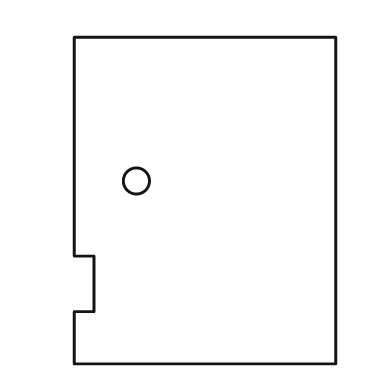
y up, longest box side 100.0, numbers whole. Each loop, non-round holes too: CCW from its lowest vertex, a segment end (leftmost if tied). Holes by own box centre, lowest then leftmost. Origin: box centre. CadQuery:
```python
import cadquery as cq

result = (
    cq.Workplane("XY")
    .moveTo(-40.0, -50.0)
    .lineTo(40.0, -50.0)
    .lineTo(40.0, 50.0)
    .lineTo(-40.0, 50.0)
    .lineTo(-40.0, -17.0)
    .lineTo(-34.0, -17.0)
    .lineTo(-34.0, -34.0)
    .lineTo(-40.0, -34.0)
    .close()
    .moveTo(-21.0, 6.0)
    .circle(4.0)
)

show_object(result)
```